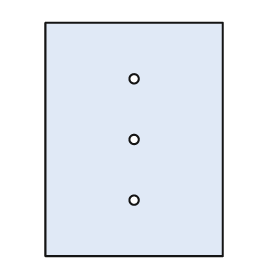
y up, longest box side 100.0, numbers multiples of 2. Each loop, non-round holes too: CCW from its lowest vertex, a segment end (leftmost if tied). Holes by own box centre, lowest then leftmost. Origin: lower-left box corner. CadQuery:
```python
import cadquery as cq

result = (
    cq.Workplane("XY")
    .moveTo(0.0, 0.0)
    .lineTo(76.0, 0.0)
    .lineTo(76.0, 100.0)
    .lineTo(0.0, 100.0)
    .close()
    .moveTo(38.0, 24.0)
    .circle(2.0)
    .moveTo(38.0, 50.0)
    .circle(2.0)
    .moveTo(38.0, 76.0)
    .circle(2.0)
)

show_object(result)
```